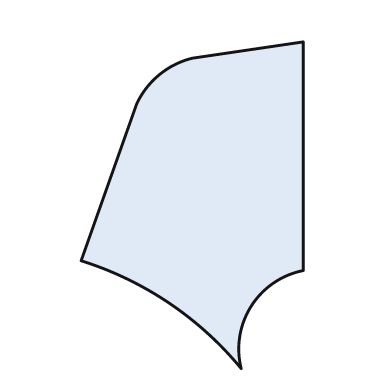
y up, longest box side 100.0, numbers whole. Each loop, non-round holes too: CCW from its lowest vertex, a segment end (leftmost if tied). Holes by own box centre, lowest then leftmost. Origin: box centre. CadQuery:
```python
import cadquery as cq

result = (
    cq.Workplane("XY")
    .moveTo(15.0, -50.0)
    .threePointArc((18.0, -31.0), (34.0, -20.0))
    .lineTo(34.0, 50.0)
    .lineTo(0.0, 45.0)
    .threePointArc((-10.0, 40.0), (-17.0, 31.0))
    .lineTo(-34.0, -17.0)
    .threePointArc((-7.0, -30.0), (15.0, -50.0))
    .close()
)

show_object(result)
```